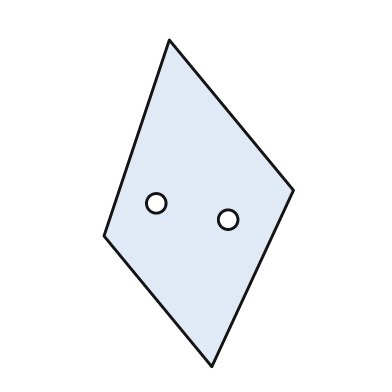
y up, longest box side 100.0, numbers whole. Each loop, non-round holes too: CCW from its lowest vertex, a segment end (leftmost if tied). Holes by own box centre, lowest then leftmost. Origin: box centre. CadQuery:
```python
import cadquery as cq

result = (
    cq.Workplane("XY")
    .moveTo(4.0, -50.0)
    .lineTo(29.0, 4.0)
    .lineTo(-9.0, 50.0)
    .lineTo(-29.0, -10.0)
    .close()
    .moveTo(9.0, -5.0)
    .circle(3.0)
    .moveTo(-13.0, 0.0)
    .circle(3.0)
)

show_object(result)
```